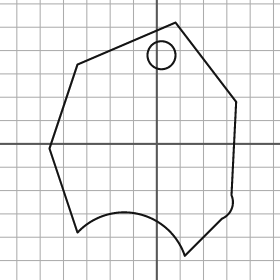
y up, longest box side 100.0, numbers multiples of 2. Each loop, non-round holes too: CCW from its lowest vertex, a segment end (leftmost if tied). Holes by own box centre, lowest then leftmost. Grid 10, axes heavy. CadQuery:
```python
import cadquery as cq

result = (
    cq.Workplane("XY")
    .moveTo(12.0, -48.0)
    .lineTo(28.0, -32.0)
    .threePointArc((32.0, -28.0), (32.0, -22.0))
    .lineTo(34.0, 18.0)
    .lineTo(8.0, 52.0)
    .lineTo(-34.0, 34.0)
    .lineTo(-46.0, -2.0)
    .lineTo(-34.0, -38.0)
    .threePointArc((-8.0, -30.0), (12.0, -48.0))
    .close()
    .moveTo(2.0, 38.0)
    .circle(6.0)
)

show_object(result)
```